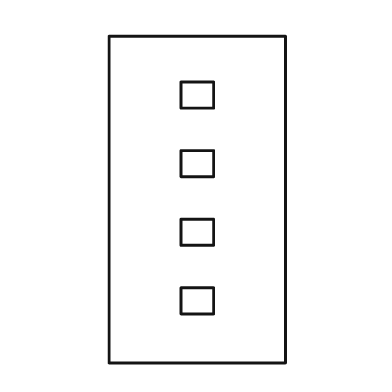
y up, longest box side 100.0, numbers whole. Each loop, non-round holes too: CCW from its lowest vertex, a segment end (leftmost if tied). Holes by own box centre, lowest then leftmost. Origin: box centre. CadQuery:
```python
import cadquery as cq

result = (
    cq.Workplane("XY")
    .moveTo(-27.0, -50.0)
    .lineTo(27.0, -50.0)
    .lineTo(27.0, 50.0)
    .lineTo(-27.0, 50.0)
    .close()
    .moveTo(-5.0, -35.0)
    .lineTo(5.0, -35.0)
    .lineTo(5.0, -27.0)
    .lineTo(-5.0, -27.0)
    .close()
    .moveTo(-5.0, -14.0)
    .lineTo(5.0, -14.0)
    .lineTo(5.0, -6.0)
    .lineTo(-5.0, -6.0)
    .close()
    .moveTo(-5.0, 7.0)
    .lineTo(5.0, 7.0)
    .lineTo(5.0, 15.0)
    .lineTo(-5.0, 15.0)
    .close()
    .moveTo(-5.0, 28.0)
    .lineTo(5.0, 28.0)
    .lineTo(5.0, 36.0)
    .lineTo(-5.0, 36.0)
    .close()
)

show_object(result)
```